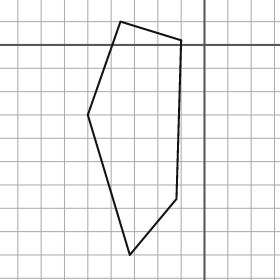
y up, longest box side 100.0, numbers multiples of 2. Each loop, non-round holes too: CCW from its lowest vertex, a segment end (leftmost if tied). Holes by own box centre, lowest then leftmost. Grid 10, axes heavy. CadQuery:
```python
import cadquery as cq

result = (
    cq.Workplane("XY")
    .moveTo(-32.0, -90.0)
    .lineTo(-12.0, -66.0)
    .lineTo(-10.0, 2.0)
    .lineTo(-36.0, 10.0)
    .lineTo(-50.0, -30.0)
    .close()
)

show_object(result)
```